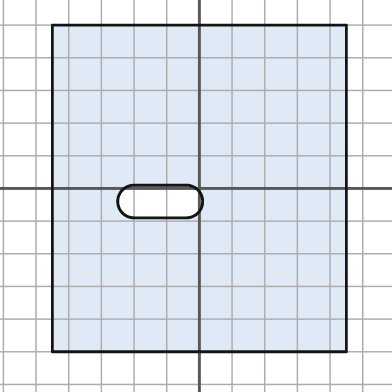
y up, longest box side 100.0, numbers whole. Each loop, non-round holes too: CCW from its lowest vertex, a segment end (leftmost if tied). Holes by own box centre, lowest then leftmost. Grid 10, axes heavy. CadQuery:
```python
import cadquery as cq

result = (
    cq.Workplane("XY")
    .moveTo(-45.0, -50.0)
    .lineTo(45.0, -50.0)
    .lineTo(45.0, 50.0)
    .lineTo(-45.0, 50.0)
    .close()
    .moveTo(-20.0, -9.0)
    .lineTo(-4.0, -9.0)
    .threePointArc((1.0, -4.0), (-4.0, 1.0))
    .lineTo(-20.0, 1.0)
    .threePointArc((-25.0, -4.0), (-20.0, -9.0))
    .close()
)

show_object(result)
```